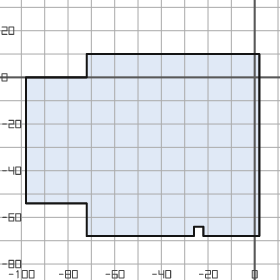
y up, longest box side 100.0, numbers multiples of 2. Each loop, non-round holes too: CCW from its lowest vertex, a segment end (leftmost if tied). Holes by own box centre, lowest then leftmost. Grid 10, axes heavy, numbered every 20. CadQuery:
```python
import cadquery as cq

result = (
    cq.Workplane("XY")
    .moveTo(-72.0, -68.0)
    .lineTo(-26.0, -68.0)
    .lineTo(-26.0, -64.0)
    .lineTo(-22.0, -64.0)
    .lineTo(-22.0, -68.0)
    .lineTo(2.0, -68.0)
    .lineTo(2.0, 10.0)
    .lineTo(-72.0, 10.0)
    .lineTo(-72.0, 0.0)
    .lineTo(-98.0, 0.0)
    .lineTo(-98.0, -54.0)
    .lineTo(-72.0, -54.0)
    .close()
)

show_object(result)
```